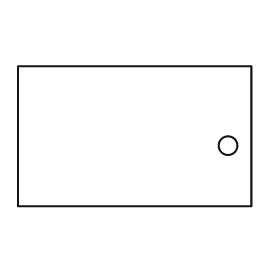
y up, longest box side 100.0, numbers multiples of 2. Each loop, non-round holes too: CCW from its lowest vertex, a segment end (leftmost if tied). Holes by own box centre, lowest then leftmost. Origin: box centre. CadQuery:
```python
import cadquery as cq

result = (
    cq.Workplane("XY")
    .moveTo(-50.0, -30.0)
    .lineTo(50.0, -30.0)
    .lineTo(50.0, 30.0)
    .lineTo(-50.0, 30.0)
    .close()
    .moveTo(40.0, -4.0)
    .circle(4.0)
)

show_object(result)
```